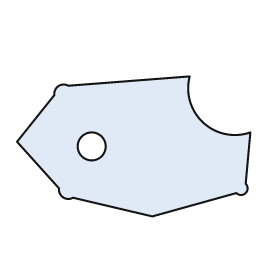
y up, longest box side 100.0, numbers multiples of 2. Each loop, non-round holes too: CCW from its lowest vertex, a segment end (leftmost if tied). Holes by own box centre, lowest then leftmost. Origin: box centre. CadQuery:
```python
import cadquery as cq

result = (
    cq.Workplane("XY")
    .moveTo(8.0, -30.0)
    .lineTo(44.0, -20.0)
    .threePointArc((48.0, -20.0), (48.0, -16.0))
    .lineTo(50.0, 6.0)
    .threePointArc((30.0, 10.0), (24.0, 30.0))
    .lineTo(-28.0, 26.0)
    .threePointArc((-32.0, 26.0), (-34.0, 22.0))
    .lineTo(-50.0, 2.0)
    .lineTo(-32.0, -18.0)
    .threePointArc((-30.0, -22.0), (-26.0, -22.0))
    .close()
    .moveTo(-18.0, 0.0)
    .circle(6.0)
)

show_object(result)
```